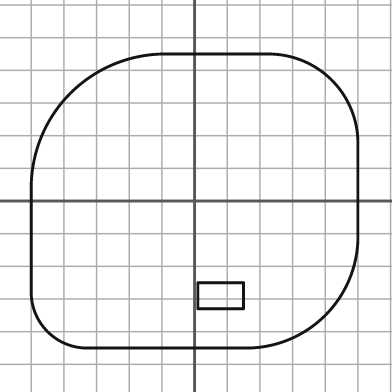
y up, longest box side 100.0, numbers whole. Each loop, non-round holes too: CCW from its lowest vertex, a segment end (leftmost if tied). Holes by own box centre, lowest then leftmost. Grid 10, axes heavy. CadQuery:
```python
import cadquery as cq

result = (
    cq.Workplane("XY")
    .moveTo(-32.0, -45.0)
    .lineTo(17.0, -45.0)
    .threePointArc((40.0, -35.0), (50.0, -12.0))
    .lineTo(50.0, 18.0)
    .threePointArc((42.0, 37.0), (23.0, 45.0))
    .lineTo(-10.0, 45.0)
    .threePointArc((-38.0, 33.0), (-50.0, 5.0))
    .lineTo(-50.0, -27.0)
    .threePointArc((-45.0, -40.0), (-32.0, -45.0))
    .close()
    .moveTo(1.0, -33.0)
    .lineTo(15.0, -33.0)
    .lineTo(15.0, -25.0)
    .lineTo(1.0, -25.0)
    .close()
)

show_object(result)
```